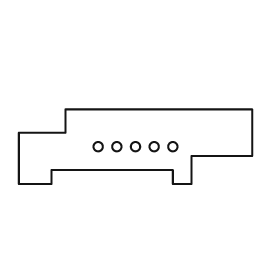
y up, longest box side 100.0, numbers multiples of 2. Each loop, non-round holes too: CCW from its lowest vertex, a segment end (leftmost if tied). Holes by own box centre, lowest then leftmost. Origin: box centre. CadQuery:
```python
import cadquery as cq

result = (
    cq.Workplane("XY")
    .moveTo(-50.0, -16.0)
    .lineTo(-36.0, -16.0)
    .lineTo(-36.0, -10.0)
    .lineTo(16.0, -10.0)
    .lineTo(16.0, -16.0)
    .lineTo(24.0, -16.0)
    .lineTo(24.0, -4.0)
    .lineTo(50.0, -4.0)
    .lineTo(50.0, 16.0)
    .lineTo(-30.0, 16.0)
    .lineTo(-30.0, 6.0)
    .lineTo(-50.0, 6.0)
    .close()
    .moveTo(-16.0, 0.0)
    .circle(2.0)
    .moveTo(-8.0, 0.0)
    .circle(2.0)
    .moveTo(0.0, 0.0)
    .circle(2.0)
    .moveTo(8.0, 0.0)
    .circle(2.0)
    .moveTo(16.0, 0.0)
    .circle(2.0)
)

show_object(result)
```